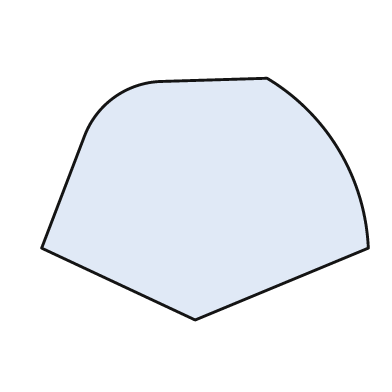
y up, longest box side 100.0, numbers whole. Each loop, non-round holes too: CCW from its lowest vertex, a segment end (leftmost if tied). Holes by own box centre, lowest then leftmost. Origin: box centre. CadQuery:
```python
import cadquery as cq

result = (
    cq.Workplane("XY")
    .moveTo(-3.0, -37.0)
    .lineTo(50.0, -15.0)
    .threePointArc((41.0, 15.0), (19.0, 37.0))
    .lineTo(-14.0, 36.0)
    .threePointArc((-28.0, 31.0), (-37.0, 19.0))
    .lineTo(-50.0, -15.0)
    .close()
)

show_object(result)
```